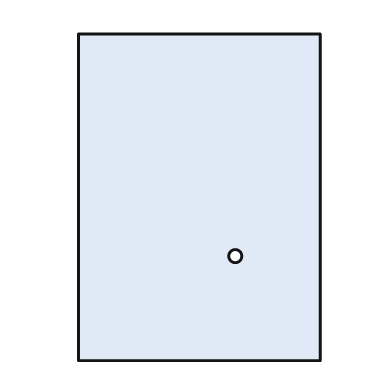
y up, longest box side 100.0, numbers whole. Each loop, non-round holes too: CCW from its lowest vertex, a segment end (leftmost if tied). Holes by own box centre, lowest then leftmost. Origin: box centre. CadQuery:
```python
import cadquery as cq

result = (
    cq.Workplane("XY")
    .moveTo(-37.0, -50.0)
    .lineTo(37.0, -50.0)
    .lineTo(37.0, 50.0)
    .lineTo(-37.0, 50.0)
    .close()
    .moveTo(11.0, -18.0)
    .circle(2.0)
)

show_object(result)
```